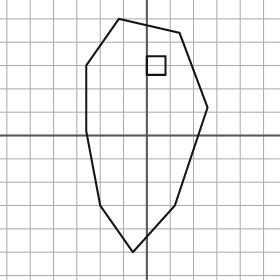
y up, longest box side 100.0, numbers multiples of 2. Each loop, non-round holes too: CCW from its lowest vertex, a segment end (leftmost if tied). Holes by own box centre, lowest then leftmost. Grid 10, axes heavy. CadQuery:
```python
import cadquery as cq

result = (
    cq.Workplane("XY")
    .moveTo(-6.0, -50.0)
    .lineTo(12.0, -30.0)
    .lineTo(26.0, 12.0)
    .lineTo(14.0, 44.0)
    .lineTo(-12.0, 50.0)
    .lineTo(-26.0, 30.0)
    .lineTo(-26.0, 2.0)
    .lineTo(-20.0, -30.0)
    .close()
    .moveTo(0.0, 26.0)
    .lineTo(8.0, 26.0)
    .lineTo(8.0, 34.0)
    .lineTo(0.0, 34.0)
    .close()
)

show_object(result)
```